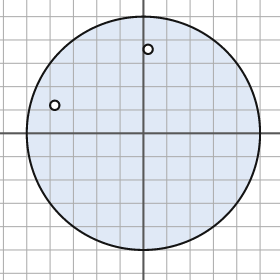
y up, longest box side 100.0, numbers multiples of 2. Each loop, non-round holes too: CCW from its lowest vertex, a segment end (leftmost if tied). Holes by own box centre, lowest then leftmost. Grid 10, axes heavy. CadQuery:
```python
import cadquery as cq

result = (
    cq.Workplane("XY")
    .moveTo(0.0, 0.0)
    .circle(50.0)
    .moveTo(-38.0, 12.0)
    .circle(2.0)
    .moveTo(2.0, 36.0)
    .circle(2.0)
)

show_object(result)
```